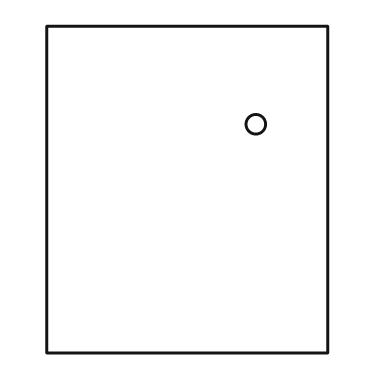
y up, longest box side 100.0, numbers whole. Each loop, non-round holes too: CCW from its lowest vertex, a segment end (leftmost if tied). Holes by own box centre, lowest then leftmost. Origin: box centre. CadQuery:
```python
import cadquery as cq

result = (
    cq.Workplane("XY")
    .moveTo(-43.0, -50.0)
    .lineTo(43.0, -50.0)
    .lineTo(43.0, 50.0)
    .lineTo(-43.0, 50.0)
    .close()
    .moveTo(21.0, 20.0)
    .circle(3.0)
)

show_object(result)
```